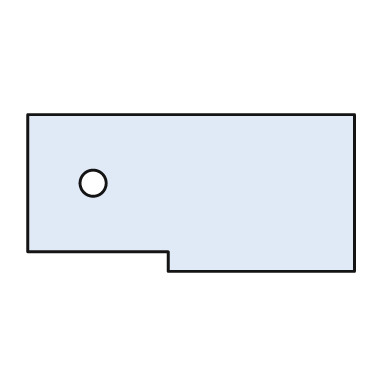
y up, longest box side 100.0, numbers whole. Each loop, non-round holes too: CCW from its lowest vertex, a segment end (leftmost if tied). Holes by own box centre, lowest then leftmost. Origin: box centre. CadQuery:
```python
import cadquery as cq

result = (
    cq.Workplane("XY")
    .moveTo(-7.0, -24.0)
    .lineTo(50.0, -24.0)
    .lineTo(50.0, 24.0)
    .lineTo(-50.0, 24.0)
    .lineTo(-50.0, -18.0)
    .lineTo(-7.0, -18.0)
    .close()
    .moveTo(-30.0, 3.0)
    .circle(4.0)
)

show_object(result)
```